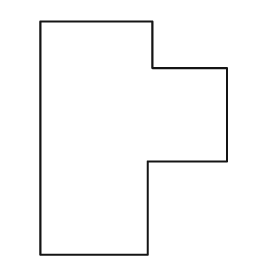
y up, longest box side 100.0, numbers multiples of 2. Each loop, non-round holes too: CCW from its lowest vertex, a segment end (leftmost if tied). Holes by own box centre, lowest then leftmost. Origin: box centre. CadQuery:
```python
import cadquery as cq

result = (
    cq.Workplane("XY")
    .moveTo(-40.0, -50.0)
    .lineTo(6.0, -50.0)
    .lineTo(6.0, -10.0)
    .lineTo(40.0, -10.0)
    .lineTo(40.0, 30.0)
    .lineTo(8.0, 30.0)
    .lineTo(8.0, 50.0)
    .lineTo(-40.0, 50.0)
    .close()
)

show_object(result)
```